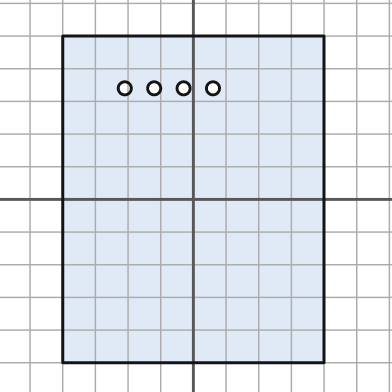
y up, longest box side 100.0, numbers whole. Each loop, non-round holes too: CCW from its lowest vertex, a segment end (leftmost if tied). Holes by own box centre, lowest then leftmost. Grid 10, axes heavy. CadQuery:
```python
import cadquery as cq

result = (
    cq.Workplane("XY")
    .moveTo(-40.0, -50.0)
    .lineTo(40.0, -50.0)
    .lineTo(40.0, 50.0)
    .lineTo(-40.0, 50.0)
    .close()
    .moveTo(-21.0, 34.0)
    .circle(2.0)
    .moveTo(-12.0, 34.0)
    .circle(2.0)
    .moveTo(-3.0, 34.0)
    .circle(2.0)
    .moveTo(6.0, 34.0)
    .circle(2.0)
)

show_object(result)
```